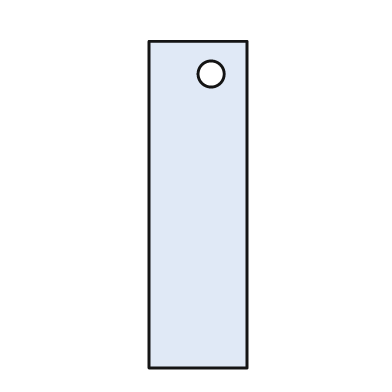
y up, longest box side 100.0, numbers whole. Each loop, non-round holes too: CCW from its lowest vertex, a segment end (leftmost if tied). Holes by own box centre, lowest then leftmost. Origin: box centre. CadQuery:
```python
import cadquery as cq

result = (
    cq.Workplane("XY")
    .moveTo(-15.0, -50.0)
    .lineTo(15.0, -50.0)
    .lineTo(15.0, 50.0)
    .lineTo(-15.0, 50.0)
    .close()
    .moveTo(4.0, 40.0)
    .circle(4.0)
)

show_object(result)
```